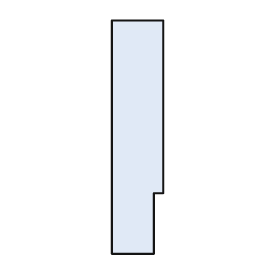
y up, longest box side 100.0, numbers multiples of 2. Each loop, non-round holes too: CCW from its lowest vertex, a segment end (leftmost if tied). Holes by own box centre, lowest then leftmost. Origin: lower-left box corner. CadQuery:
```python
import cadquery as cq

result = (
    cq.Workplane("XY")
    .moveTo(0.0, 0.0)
    .lineTo(18.0, 0.0)
    .lineTo(18.0, 26.0)
    .lineTo(22.0, 26.0)
    .lineTo(22.0, 100.0)
    .lineTo(0.0, 100.0)
    .close()
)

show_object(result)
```